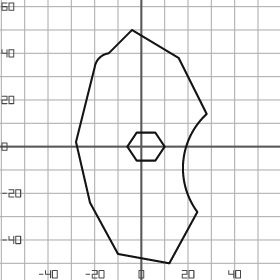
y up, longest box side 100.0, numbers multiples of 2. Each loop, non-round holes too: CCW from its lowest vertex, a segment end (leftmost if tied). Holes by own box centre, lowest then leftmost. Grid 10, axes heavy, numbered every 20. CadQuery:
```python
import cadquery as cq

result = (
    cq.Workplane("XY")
    .moveTo(12.0, -50.0)
    .lineTo(24.0, -28.0)
    .threePointArc((18.0, -6.0), (28.0, 14.0))
    .lineTo(16.0, 38.0)
    .lineTo(-4.0, 50.0)
    .lineTo(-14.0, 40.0)
    .threePointArc((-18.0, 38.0), (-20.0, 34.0))
    .lineTo(-28.0, 2.0)
    .lineTo(-22.0, -24.0)
    .lineTo(-10.0, -46.0)
    .close()
    .moveTo(-2.0, -6.0)
    .lineTo(6.0, -6.0)
    .lineTo(10.0, 0.0)
    .lineTo(6.0, 6.0)
    .lineTo(-2.0, 6.0)
    .lineTo(-6.0, 0.0)
    .close()
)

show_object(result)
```